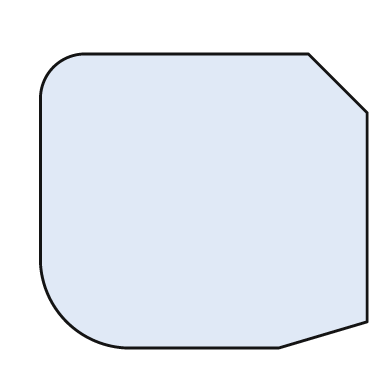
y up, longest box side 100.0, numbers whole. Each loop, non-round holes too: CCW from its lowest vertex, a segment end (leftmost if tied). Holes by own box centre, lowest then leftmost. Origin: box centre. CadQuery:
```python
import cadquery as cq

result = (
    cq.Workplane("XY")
    .moveTo(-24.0, -45.0)
    .lineTo(23.0, -45.0)
    .lineTo(50.0, -37.0)
    .lineTo(50.0, 27.0)
    .lineTo(32.0, 45.0)
    .lineTo(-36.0, 45.0)
    .threePointArc((-46.0, 41.0), (-50.0, 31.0))
    .lineTo(-50.0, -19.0)
    .threePointArc((-42.0, -37.0), (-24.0, -45.0))
    .close()
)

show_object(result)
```